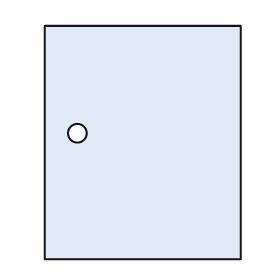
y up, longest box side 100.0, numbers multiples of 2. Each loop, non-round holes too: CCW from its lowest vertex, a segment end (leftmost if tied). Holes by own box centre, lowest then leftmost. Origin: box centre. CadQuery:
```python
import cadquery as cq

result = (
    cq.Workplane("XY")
    .moveTo(-42.0, -50.0)
    .lineTo(42.0, -50.0)
    .lineTo(42.0, 50.0)
    .lineTo(-42.0, 50.0)
    .close()
    .moveTo(-28.0, 4.0)
    .circle(4.0)
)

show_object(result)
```